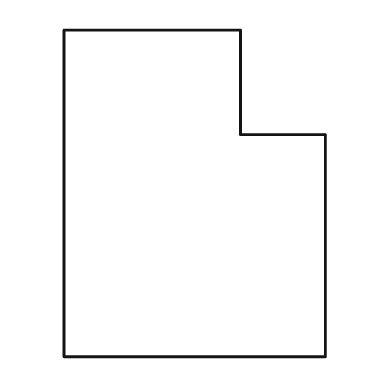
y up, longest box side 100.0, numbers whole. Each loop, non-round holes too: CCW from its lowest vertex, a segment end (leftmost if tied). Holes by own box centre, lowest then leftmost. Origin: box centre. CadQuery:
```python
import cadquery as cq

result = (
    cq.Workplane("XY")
    .moveTo(-40.0, -50.0)
    .lineTo(40.0, -50.0)
    .lineTo(40.0, 18.0)
    .lineTo(14.0, 18.0)
    .lineTo(14.0, 50.0)
    .lineTo(-40.0, 50.0)
    .close()
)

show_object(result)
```